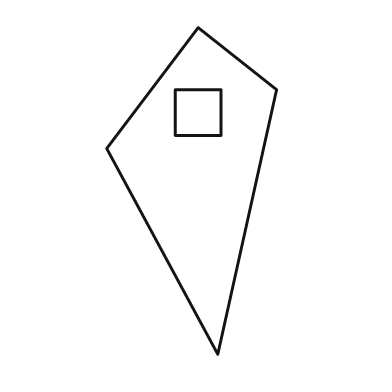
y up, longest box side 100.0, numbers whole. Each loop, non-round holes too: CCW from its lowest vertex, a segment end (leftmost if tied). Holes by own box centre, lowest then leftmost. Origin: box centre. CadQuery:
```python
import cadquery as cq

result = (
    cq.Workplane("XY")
    .moveTo(8.0, -50.0)
    .lineTo(26.0, 31.0)
    .lineTo(2.0, 50.0)
    .lineTo(-26.0, 13.0)
    .close()
    .moveTo(-5.0, 17.0)
    .lineTo(9.0, 17.0)
    .lineTo(9.0, 31.0)
    .lineTo(-5.0, 31.0)
    .close()
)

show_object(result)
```